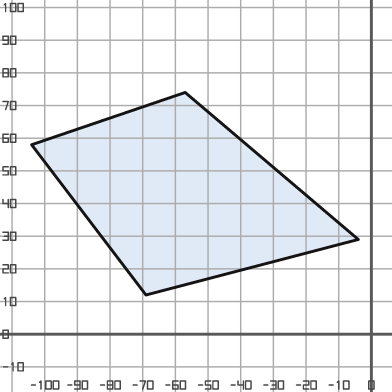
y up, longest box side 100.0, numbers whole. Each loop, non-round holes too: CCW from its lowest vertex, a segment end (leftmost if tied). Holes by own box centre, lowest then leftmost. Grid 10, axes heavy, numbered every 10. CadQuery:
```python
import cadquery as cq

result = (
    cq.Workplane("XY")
    .moveTo(-69.0, 12.0)
    .lineTo(-4.0, 29.0)
    .lineTo(-57.0, 74.0)
    .lineTo(-104.0, 58.0)
    .close()
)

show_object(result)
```